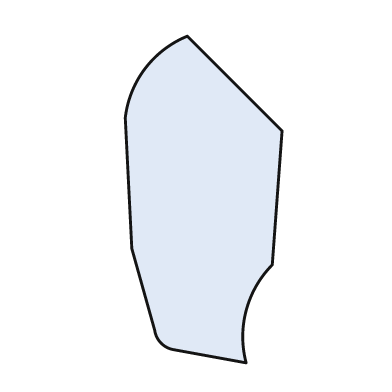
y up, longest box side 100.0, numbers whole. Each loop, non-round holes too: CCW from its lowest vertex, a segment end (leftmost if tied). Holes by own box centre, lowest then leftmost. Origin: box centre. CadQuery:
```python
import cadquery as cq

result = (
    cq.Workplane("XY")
    .moveTo(13.0, -50.0)
    .threePointArc((13.0, -34.0), (21.0, -20.0))
    .lineTo(24.0, 21.0)
    .lineTo(-5.0, 50.0)
    .threePointArc((-18.0, 40.0), (-24.0, 25.0))
    .lineTo(-22.0, -15.0)
    .lineTo(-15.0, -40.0)
    .threePointArc((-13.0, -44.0), (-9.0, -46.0))
    .close()
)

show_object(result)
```